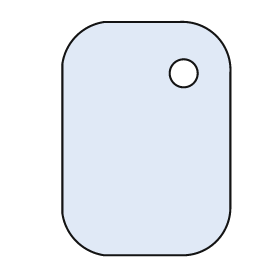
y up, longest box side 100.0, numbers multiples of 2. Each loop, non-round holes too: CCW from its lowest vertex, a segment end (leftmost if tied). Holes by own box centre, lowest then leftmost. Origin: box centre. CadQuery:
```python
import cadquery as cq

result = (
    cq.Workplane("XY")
    .moveTo(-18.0, -50.0)
    .lineTo(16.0, -50.0)
    .threePointArc((30.0, -44.0), (36.0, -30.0))
    .lineTo(36.0, 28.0)
    .threePointArc((30.0, 44.0), (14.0, 50.0))
    .lineTo(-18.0, 50.0)
    .threePointArc((-30.0, 44.0), (-36.0, 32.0))
    .lineTo(-36.0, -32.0)
    .threePointArc((-30.0, -44.0), (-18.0, -50.0))
    .close()
    .moveTo(16.0, 28.0)
    .circle(6.0)
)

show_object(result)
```